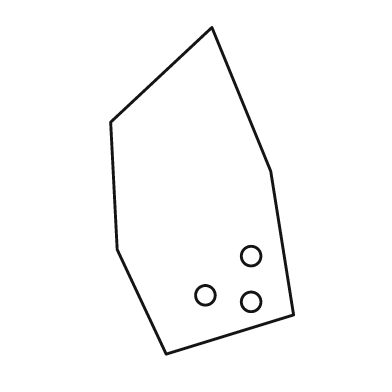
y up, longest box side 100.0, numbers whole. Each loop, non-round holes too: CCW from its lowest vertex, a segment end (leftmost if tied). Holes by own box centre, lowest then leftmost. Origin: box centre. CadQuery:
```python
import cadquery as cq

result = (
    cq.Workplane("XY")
    .moveTo(-11.0, -50.0)
    .lineTo(28.0, -38.0)
    .lineTo(21.0, 6.0)
    .lineTo(3.0, 50.0)
    .lineTo(-28.0, 21.0)
    .lineTo(-26.0, -18.0)
    .close()
    .moveTo(15.0, -34.0)
    .circle(3.0)
    .moveTo(1.0, -32.0)
    .circle(3.0)
    .moveTo(15.0, -20.0)
    .circle(3.0)
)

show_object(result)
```